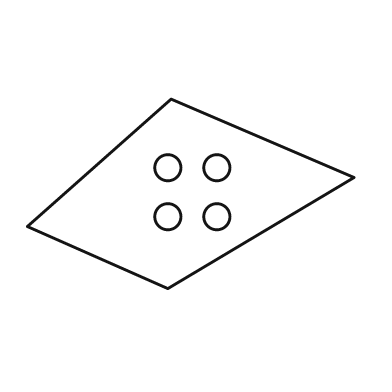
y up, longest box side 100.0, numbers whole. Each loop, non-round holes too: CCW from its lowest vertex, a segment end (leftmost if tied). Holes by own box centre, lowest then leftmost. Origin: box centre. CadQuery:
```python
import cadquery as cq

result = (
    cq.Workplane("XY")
    .moveTo(-7.0, -29.0)
    .lineTo(50.0, 5.0)
    .lineTo(-6.0, 29.0)
    .lineTo(-50.0, -10.0)
    .close()
    .moveTo(-7.0, -7.0)
    .circle(4.0)
    .moveTo(8.0, -7.0)
    .circle(4.0)
    .moveTo(-7.0, 8.0)
    .circle(4.0)
    .moveTo(8.0, 8.0)
    .circle(4.0)
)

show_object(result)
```